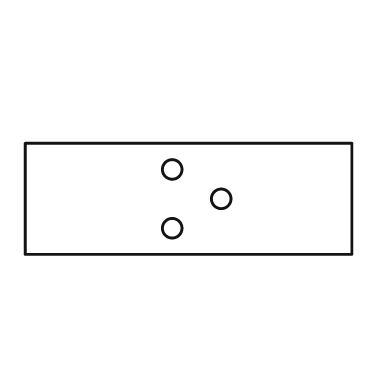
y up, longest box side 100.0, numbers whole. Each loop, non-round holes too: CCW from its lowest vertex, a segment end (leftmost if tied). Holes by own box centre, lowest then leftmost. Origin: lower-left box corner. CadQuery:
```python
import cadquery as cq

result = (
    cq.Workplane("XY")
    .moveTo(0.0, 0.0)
    .lineTo(100.0, 0.0)
    .lineTo(100.0, 34.0)
    .lineTo(0.0, 34.0)
    .close()
    .moveTo(45.0, 8.0)
    .circle(3.0)
    .moveTo(60.0, 17.0)
    .circle(3.0)
    .moveTo(45.0, 26.0)
    .circle(3.0)
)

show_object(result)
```